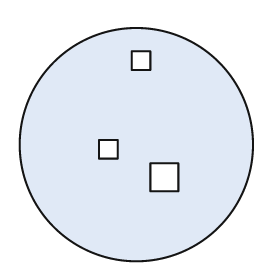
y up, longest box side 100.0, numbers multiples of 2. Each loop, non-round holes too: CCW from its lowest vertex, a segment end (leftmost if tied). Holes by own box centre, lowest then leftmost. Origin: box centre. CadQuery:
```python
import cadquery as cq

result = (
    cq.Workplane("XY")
    .moveTo(0.0, 0.0)
    .circle(50.0)
    .moveTo(6.0, -20.0)
    .lineTo(18.0, -20.0)
    .lineTo(18.0, -8.0)
    .lineTo(6.0, -8.0)
    .close()
    .moveTo(-16.0, -6.0)
    .lineTo(-8.0, -6.0)
    .lineTo(-8.0, 2.0)
    .lineTo(-16.0, 2.0)
    .close()
    .moveTo(-2.0, 32.0)
    .lineTo(6.0, 32.0)
    .lineTo(6.0, 40.0)
    .lineTo(-2.0, 40.0)
    .close()
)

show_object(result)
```